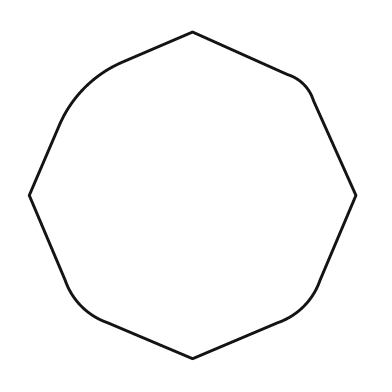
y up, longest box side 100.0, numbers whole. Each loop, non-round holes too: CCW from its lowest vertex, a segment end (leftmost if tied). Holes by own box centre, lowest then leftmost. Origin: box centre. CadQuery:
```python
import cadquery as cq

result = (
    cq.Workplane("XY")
    .moveTo(0.0, -50.0)
    .lineTo(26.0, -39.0)
    .threePointArc((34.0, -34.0), (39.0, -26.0))
    .lineTo(50.0, 0.0)
    .lineTo(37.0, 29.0)
    .threePointArc((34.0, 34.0), (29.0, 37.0))
    .lineTo(0.0, 50.0)
    .lineTo(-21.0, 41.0)
    .threePointArc((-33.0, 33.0), (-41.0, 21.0))
    .lineTo(-50.0, 0.0)
    .lineTo(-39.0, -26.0)
    .threePointArc((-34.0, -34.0), (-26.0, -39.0))
    .close()
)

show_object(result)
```